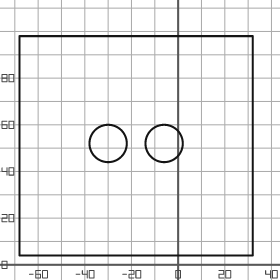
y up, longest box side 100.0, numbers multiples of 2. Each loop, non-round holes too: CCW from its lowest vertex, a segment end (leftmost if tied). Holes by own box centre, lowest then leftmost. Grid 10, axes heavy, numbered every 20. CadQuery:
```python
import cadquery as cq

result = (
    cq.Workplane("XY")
    .moveTo(-68.0, 4.0)
    .lineTo(32.0, 4.0)
    .lineTo(32.0, 98.0)
    .lineTo(-68.0, 98.0)
    .close()
    .moveTo(-30.0, 52.0)
    .circle(8.0)
    .moveTo(-6.0, 52.0)
    .circle(8.0)
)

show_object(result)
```